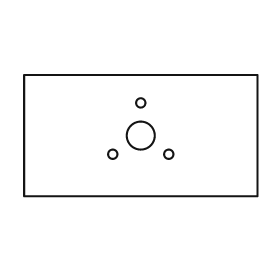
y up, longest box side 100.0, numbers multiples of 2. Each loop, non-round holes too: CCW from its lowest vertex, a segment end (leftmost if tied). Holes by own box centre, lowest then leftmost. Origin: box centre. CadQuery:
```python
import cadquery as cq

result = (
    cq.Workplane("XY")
    .moveTo(-50.0, -26.0)
    .lineTo(50.0, -26.0)
    .lineTo(50.0, 26.0)
    .lineTo(-50.0, 26.0)
    .close()
    .moveTo(-12.0, -8.0)
    .circle(2.0)
    .moveTo(12.0, -8.0)
    .circle(2.0)
    .moveTo(0.0, 0.0)
    .circle(6.0)
    .moveTo(0.0, 14.0)
    .circle(2.0)
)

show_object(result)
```